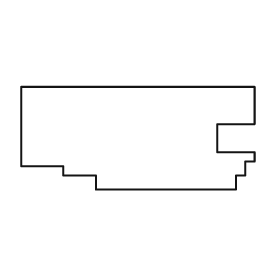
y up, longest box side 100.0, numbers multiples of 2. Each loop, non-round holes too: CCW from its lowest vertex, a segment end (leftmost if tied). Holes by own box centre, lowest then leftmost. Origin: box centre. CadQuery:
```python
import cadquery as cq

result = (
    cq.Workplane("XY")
    .moveTo(-18.0, -22.0)
    .lineTo(42.0, -22.0)
    .lineTo(42.0, -16.0)
    .lineTo(46.0, -16.0)
    .lineTo(46.0, -10.0)
    .lineTo(50.0, -10.0)
    .lineTo(50.0, -6.0)
    .lineTo(34.0, -6.0)
    .lineTo(34.0, 6.0)
    .lineTo(50.0, 6.0)
    .lineTo(50.0, 22.0)
    .lineTo(-50.0, 22.0)
    .lineTo(-50.0, -12.0)
    .lineTo(-32.0, -12.0)
    .lineTo(-32.0, -16.0)
    .lineTo(-18.0, -16.0)
    .close()
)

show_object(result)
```